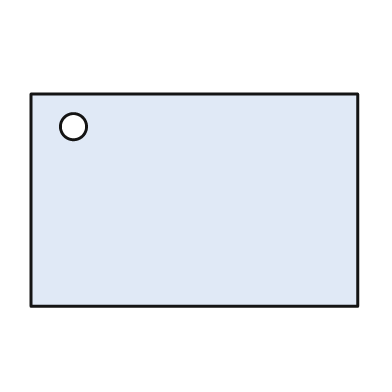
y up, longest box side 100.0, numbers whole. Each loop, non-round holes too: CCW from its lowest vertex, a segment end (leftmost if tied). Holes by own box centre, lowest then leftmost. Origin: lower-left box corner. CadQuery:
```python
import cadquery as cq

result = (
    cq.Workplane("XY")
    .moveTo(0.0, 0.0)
    .lineTo(100.0, 0.0)
    .lineTo(100.0, 65.0)
    .lineTo(0.0, 65.0)
    .close()
    .moveTo(13.0, 55.0)
    .circle(4.0)
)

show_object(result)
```